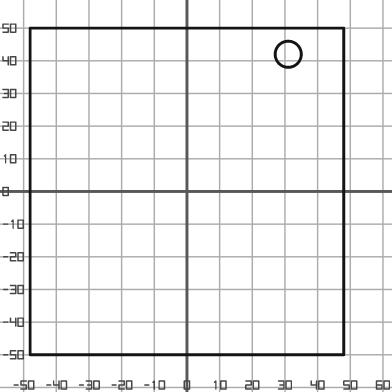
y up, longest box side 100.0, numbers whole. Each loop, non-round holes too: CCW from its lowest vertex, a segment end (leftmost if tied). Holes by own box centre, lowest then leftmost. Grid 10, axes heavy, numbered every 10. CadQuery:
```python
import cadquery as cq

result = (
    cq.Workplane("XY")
    .moveTo(-48.0, -50.0)
    .lineTo(48.0, -50.0)
    .lineTo(48.0, 50.0)
    .lineTo(-48.0, 50.0)
    .close()
    .moveTo(31.0, 42.0)
    .circle(4.0)
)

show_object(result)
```